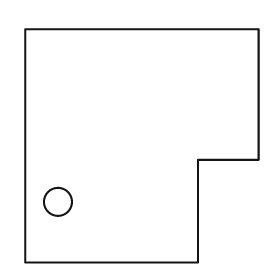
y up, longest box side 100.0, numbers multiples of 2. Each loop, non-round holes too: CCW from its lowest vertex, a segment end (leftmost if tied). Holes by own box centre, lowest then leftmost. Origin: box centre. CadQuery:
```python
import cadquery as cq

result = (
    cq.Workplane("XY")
    .moveTo(-50.0, -50.0)
    .lineTo(24.0, -50.0)
    .lineTo(24.0, -6.0)
    .lineTo(50.0, -6.0)
    .lineTo(50.0, 50.0)
    .lineTo(-50.0, 50.0)
    .close()
    .moveTo(-36.0, -24.0)
    .circle(6.0)
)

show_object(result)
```